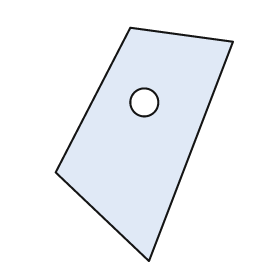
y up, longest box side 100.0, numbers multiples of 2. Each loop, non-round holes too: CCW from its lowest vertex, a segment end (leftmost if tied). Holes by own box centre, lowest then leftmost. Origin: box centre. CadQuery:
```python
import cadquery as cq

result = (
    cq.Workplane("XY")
    .moveTo(2.0, -50.0)
    .lineTo(38.0, 44.0)
    .lineTo(-6.0, 50.0)
    .lineTo(-38.0, -12.0)
    .close()
    .moveTo(0.0, 18.0)
    .circle(6.0)
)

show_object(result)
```